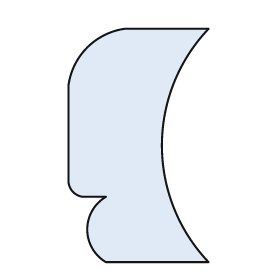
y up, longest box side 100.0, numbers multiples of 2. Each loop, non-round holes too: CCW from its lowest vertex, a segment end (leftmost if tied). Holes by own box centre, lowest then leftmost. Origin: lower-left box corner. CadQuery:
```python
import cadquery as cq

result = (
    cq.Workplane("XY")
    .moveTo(16.0, 0.0)
    .lineTo(60.0, 0.0)
    .threePointArc((40.0, 50.0), (60.0, 100.0))
    .lineTo(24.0, 100.0)
    .threePointArc((8.0, 92.0), (0.0, 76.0))
    .lineTo(0.0, 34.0)
    .threePointArc((2.0, 30.0), (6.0, 28.0))
    .lineTo(16.0, 28.0)
    .threePointArc((8.0, 14.0), (16.0, 0.0))
    .close()
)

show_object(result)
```